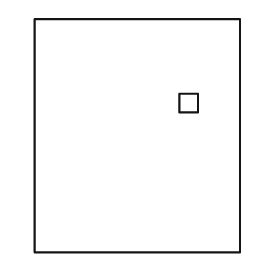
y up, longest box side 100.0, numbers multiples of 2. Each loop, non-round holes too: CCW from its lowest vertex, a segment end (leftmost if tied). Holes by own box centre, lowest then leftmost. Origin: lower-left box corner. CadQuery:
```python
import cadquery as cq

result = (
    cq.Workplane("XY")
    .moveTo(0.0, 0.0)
    .lineTo(88.0, 0.0)
    .lineTo(88.0, 100.0)
    .lineTo(0.0, 100.0)
    .close()
    .moveTo(62.0, 60.0)
    .lineTo(70.0, 60.0)
    .lineTo(70.0, 68.0)
    .lineTo(62.0, 68.0)
    .close()
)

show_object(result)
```